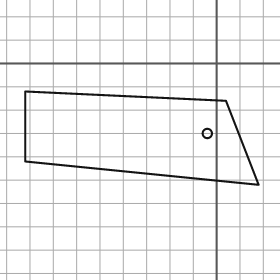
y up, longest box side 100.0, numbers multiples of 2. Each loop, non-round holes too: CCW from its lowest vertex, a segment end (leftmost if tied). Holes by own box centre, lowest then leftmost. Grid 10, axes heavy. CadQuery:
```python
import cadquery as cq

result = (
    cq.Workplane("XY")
    .moveTo(18.0, -52.0)
    .lineTo(4.0, -16.0)
    .lineTo(-82.0, -12.0)
    .lineTo(-82.0, -42.0)
    .close()
    .moveTo(-4.0, -30.0)
    .circle(2.0)
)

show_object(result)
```